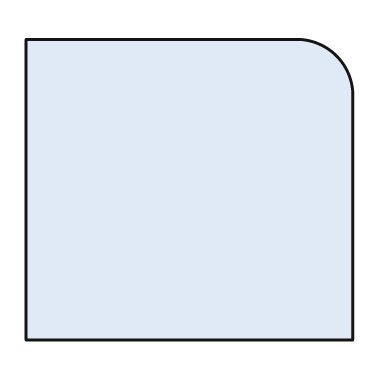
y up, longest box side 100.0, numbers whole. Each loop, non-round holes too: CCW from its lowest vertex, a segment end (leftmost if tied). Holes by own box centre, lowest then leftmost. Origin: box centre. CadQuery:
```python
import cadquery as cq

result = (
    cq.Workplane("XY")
    .moveTo(-50.0, -46.0)
    .lineTo(50.0, -46.0)
    .lineTo(50.0, 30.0)
    .threePointArc((45.0, 41.0), (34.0, 46.0))
    .lineTo(-50.0, 46.0)
    .close()
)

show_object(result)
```